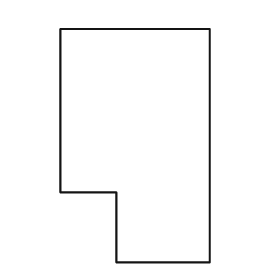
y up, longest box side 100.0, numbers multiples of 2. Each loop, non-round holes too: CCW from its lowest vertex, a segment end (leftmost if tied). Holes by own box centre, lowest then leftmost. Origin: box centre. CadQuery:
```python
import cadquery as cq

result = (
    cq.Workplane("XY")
    .moveTo(-8.0, -50.0)
    .lineTo(32.0, -50.0)
    .lineTo(32.0, 50.0)
    .lineTo(-32.0, 50.0)
    .lineTo(-32.0, -20.0)
    .lineTo(-8.0, -20.0)
    .close()
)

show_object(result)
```